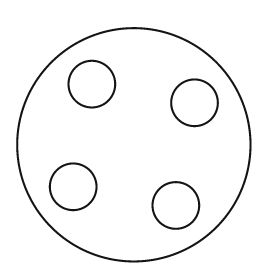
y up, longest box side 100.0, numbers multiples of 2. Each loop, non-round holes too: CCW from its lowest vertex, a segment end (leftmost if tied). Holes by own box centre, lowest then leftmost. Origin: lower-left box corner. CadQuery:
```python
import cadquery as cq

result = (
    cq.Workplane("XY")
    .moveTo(50.0, 50.0)
    .circle(50.0)
    .moveTo(68.0, 24.0)
    .circle(10.0)
    .moveTo(24.0, 32.0)
    .circle(10.0)
    .moveTo(76.0, 68.0)
    .circle(10.0)
    .moveTo(32.0, 76.0)
    .circle(10.0)
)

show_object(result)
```